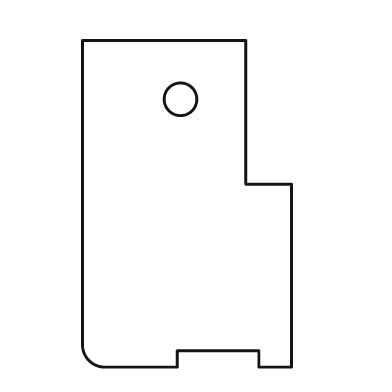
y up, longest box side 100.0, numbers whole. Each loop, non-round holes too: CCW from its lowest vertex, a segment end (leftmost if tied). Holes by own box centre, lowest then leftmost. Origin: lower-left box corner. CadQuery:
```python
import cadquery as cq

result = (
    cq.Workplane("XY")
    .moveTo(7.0, 0.0)
    .lineTo(29.0, 0.0)
    .lineTo(29.0, 5.0)
    .lineTo(54.0, 5.0)
    .lineTo(54.0, 0.0)
    .lineTo(64.0, 0.0)
    .lineTo(64.0, 56.0)
    .lineTo(50.0, 56.0)
    .lineTo(50.0, 100.0)
    .lineTo(0.0, 100.0)
    .lineTo(0.0, 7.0)
    .threePointArc((2.0, 2.0), (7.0, 0.0))
    .close()
    .moveTo(30.0, 82.0)
    .circle(5.0)
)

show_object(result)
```